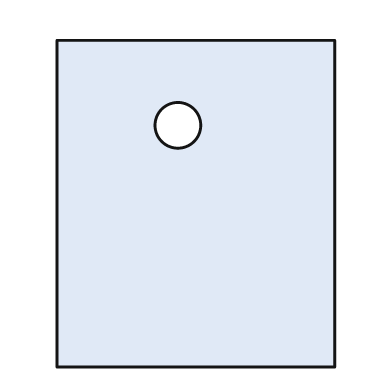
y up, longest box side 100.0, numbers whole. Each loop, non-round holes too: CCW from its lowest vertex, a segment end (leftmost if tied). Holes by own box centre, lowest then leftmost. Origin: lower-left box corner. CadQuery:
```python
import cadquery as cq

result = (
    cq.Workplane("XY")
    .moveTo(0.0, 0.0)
    .lineTo(85.0, 0.0)
    .lineTo(85.0, 100.0)
    .lineTo(0.0, 100.0)
    .close()
    .moveTo(37.0, 74.0)
    .circle(7.0)
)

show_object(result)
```